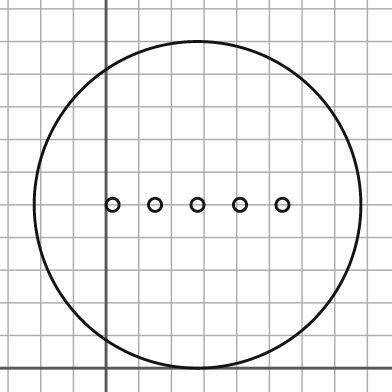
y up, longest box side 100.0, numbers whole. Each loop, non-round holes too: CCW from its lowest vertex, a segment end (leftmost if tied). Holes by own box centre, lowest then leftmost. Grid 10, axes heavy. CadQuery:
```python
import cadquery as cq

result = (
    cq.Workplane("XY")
    .moveTo(28.0, 50.0)
    .circle(50.0)
    .moveTo(2.0, 50.0)
    .circle(2.0)
    .moveTo(15.0, 50.0)
    .circle(2.0)
    .moveTo(28.0, 50.0)
    .circle(2.0)
    .moveTo(41.0, 50.0)
    .circle(2.0)
    .moveTo(54.0, 50.0)
    .circle(2.0)
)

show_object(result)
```